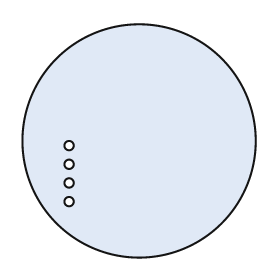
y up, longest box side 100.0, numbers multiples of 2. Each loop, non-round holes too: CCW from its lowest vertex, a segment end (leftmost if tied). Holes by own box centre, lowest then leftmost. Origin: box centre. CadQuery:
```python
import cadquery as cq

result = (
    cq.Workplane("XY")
    .moveTo(0.0, 0.0)
    .circle(50.0)
    .moveTo(-30.0, -26.0)
    .circle(2.0)
    .moveTo(-30.0, -18.0)
    .circle(2.0)
    .moveTo(-30.0, -10.0)
    .circle(2.0)
    .moveTo(-30.0, -2.0)
    .circle(2.0)
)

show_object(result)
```